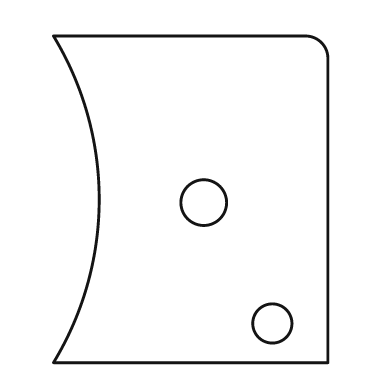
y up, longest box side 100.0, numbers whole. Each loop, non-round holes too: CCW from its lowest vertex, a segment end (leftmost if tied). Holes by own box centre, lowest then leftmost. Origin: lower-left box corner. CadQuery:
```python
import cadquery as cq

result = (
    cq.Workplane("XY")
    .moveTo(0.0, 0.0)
    .lineTo(84.0, 0.0)
    .lineTo(84.0, 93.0)
    .threePointArc((82.0, 98.0), (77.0, 100.0))
    .lineTo(0.0, 100.0)
    .threePointArc((14.0, 50.0), (0.0, 0.0))
    .close()
    .moveTo(67.0, 12.0)
    .circle(6.0)
    .moveTo(46.0, 49.0)
    .circle(7.0)
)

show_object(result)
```